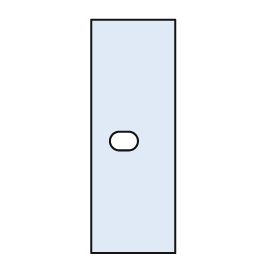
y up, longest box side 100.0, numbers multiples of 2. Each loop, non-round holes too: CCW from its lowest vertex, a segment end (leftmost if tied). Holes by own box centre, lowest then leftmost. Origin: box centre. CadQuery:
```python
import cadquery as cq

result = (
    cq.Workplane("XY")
    .moveTo(-18.0, -50.0)
    .lineTo(18.0, -50.0)
    .lineTo(18.0, 50.0)
    .lineTo(-18.0, 50.0)
    .close()
    .moveTo(-6.0, -6.0)
    .lineTo(-2.0, -6.0)
    .threePointArc((2.0, -2.0), (-2.0, 2.0))
    .lineTo(-6.0, 2.0)
    .threePointArc((-10.0, -2.0), (-6.0, -6.0))
    .close()
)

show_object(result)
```